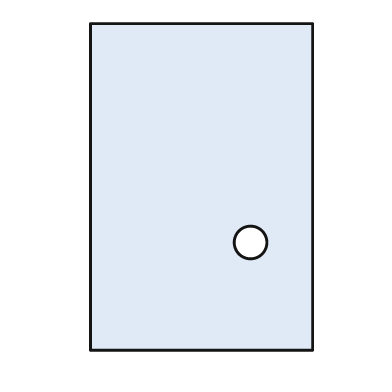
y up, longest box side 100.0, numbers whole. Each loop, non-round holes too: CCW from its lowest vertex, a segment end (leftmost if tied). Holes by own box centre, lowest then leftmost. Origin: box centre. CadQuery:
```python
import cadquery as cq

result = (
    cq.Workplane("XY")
    .moveTo(-34.0, -50.0)
    .lineTo(34.0, -50.0)
    .lineTo(34.0, 50.0)
    .lineTo(-34.0, 50.0)
    .close()
    .moveTo(15.0, -17.0)
    .circle(5.0)
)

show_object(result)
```